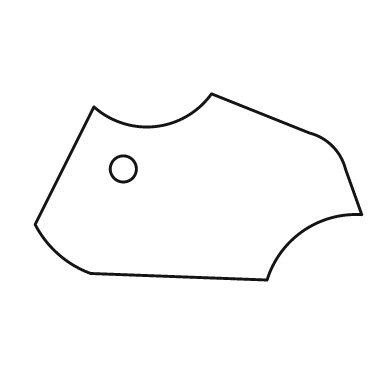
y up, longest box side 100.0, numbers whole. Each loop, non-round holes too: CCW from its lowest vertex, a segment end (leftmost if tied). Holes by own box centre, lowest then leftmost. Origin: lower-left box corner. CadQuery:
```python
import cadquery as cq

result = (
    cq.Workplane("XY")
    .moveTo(71.0, 0.0)
    .threePointArc((82.0, 15.0), (100.0, 20.0))
    .lineTo(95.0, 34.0)
    .threePointArc((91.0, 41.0), (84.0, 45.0))
    .lineTo(54.0, 57.0)
    .threePointArc((37.0, 47.0), (18.0, 53.0))
    .lineTo(0.0, 17.0)
    .threePointArc((7.0, 8.0), (17.0, 2.0))
    .close()
    .moveTo(27.0, 34.0)
    .circle(4.0)
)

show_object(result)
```